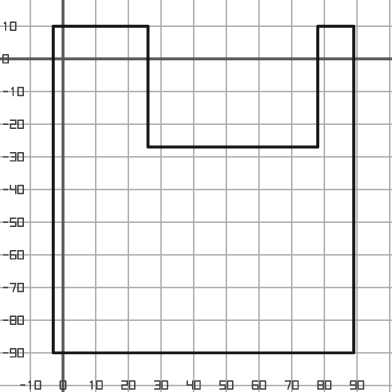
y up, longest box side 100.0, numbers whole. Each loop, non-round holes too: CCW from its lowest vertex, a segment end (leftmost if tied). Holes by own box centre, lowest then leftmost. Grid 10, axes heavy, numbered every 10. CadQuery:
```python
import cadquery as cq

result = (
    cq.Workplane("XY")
    .moveTo(-3.0, -90.0)
    .lineTo(89.0, -90.0)
    .lineTo(89.0, 10.0)
    .lineTo(78.0, 10.0)
    .lineTo(78.0, -27.0)
    .lineTo(26.0, -27.0)
    .lineTo(26.0, 10.0)
    .lineTo(-3.0, 10.0)
    .close()
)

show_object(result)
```